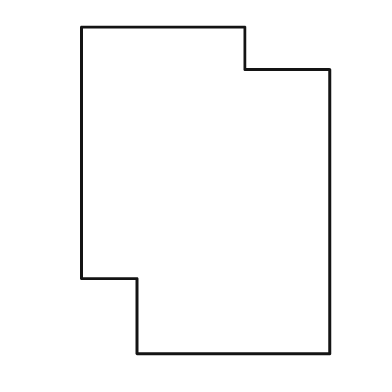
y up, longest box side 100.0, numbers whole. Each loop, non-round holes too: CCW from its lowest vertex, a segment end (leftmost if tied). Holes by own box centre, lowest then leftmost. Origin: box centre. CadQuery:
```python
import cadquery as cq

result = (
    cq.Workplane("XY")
    .moveTo(-21.0, -50.0)
    .lineTo(38.0, -50.0)
    .lineTo(38.0, 37.0)
    .lineTo(12.0, 37.0)
    .lineTo(12.0, 50.0)
    .lineTo(-38.0, 50.0)
    .lineTo(-38.0, -27.0)
    .lineTo(-21.0, -27.0)
    .close()
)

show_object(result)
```